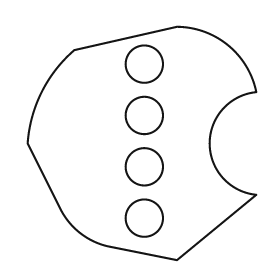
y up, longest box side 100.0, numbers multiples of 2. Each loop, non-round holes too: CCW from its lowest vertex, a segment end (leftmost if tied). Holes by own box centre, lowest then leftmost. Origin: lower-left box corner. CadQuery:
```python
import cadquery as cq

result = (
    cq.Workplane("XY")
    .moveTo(64.0, 0.0)
    .lineTo(98.0, 28.0)
    .threePointArc((78.0, 50.0), (98.0, 72.0))
    .threePointArc((86.0, 92.0), (64.0, 100.0))
    .lineTo(20.0, 90.0)
    .threePointArc((6.0, 72.0), (0.0, 50.0))
    .lineTo(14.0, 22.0)
    .threePointArc((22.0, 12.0), (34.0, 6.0))
    .close()
    .moveTo(50.0, 18.0)
    .circle(8.0)
    .moveTo(50.0, 40.0)
    .circle(8.0)
    .moveTo(50.0, 62.0)
    .circle(8.0)
    .moveTo(50.0, 84.0)
    .circle(8.0)
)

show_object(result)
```